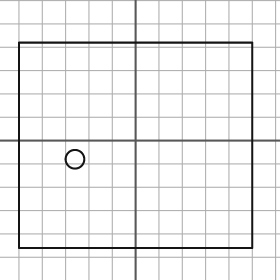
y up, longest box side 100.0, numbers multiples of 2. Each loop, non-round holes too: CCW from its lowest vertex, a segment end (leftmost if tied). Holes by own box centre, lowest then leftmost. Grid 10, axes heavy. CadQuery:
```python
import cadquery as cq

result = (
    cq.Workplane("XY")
    .moveTo(-50.0, -46.0)
    .lineTo(50.0, -46.0)
    .lineTo(50.0, 42.0)
    .lineTo(-50.0, 42.0)
    .close()
    .moveTo(-26.0, -8.0)
    .circle(4.0)
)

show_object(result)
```